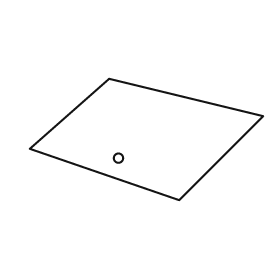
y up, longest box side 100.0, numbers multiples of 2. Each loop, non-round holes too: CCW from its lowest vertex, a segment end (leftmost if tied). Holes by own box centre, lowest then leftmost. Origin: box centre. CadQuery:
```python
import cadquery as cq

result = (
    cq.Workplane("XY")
    .moveTo(14.0, -26.0)
    .lineTo(50.0, 10.0)
    .lineTo(-16.0, 26.0)
    .lineTo(-50.0, -4.0)
    .close()
    .moveTo(-12.0, -8.0)
    .circle(2.0)
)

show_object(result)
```